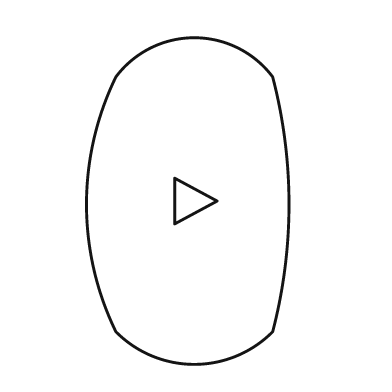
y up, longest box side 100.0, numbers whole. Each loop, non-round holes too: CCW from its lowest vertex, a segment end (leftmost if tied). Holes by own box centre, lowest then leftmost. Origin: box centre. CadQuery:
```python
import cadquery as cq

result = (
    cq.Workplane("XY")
    .moveTo(-22.0, -40.0)
    .threePointArc((2.0, -50.0), (26.0, -40.0))
    .threePointArc((31.0, -1.0), (26.0, 38.0))
    .threePointArc((2.0, 50.0), (-22.0, 38.0))
    .threePointArc((-31.0, -1.0), (-22.0, -40.0))
    .close()
    .moveTo(-4.0, -7.0)
    .lineTo(9.0, 0.0)
    .lineTo(-4.0, 7.0)
    .close()
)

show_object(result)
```